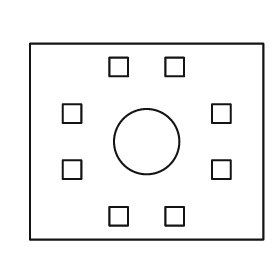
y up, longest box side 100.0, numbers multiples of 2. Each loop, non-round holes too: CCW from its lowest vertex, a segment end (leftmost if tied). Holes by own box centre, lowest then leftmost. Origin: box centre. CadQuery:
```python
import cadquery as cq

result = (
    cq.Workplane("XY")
    .moveTo(-50.0, -42.0)
    .lineTo(50.0, -42.0)
    .lineTo(50.0, 42.0)
    .lineTo(-50.0, 42.0)
    .close()
    .moveTo(-16.0, -36.0)
    .lineTo(-8.0, -36.0)
    .lineTo(-8.0, -28.0)
    .lineTo(-16.0, -28.0)
    .close()
    .moveTo(8.0, -36.0)
    .lineTo(16.0, -36.0)
    .lineTo(16.0, -28.0)
    .lineTo(8.0, -28.0)
    .close()
    .moveTo(-36.0, -16.0)
    .lineTo(-28.0, -16.0)
    .lineTo(-28.0, -8.0)
    .lineTo(-36.0, -8.0)
    .close()
    .moveTo(28.0, -16.0)
    .lineTo(36.0, -16.0)
    .lineTo(36.0, -8.0)
    .lineTo(28.0, -8.0)
    .close()
    .moveTo(0.0, 0.0)
    .circle(14.0)
    .moveTo(-36.0, 8.0)
    .lineTo(-28.0, 8.0)
    .lineTo(-28.0, 16.0)
    .lineTo(-36.0, 16.0)
    .close()
    .moveTo(28.0, 8.0)
    .lineTo(36.0, 8.0)
    .lineTo(36.0, 16.0)
    .lineTo(28.0, 16.0)
    .close()
    .moveTo(-16.0, 28.0)
    .lineTo(-8.0, 28.0)
    .lineTo(-8.0, 36.0)
    .lineTo(-16.0, 36.0)
    .close()
    .moveTo(8.0, 28.0)
    .lineTo(16.0, 28.0)
    .lineTo(16.0, 36.0)
    .lineTo(8.0, 36.0)
    .close()
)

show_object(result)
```